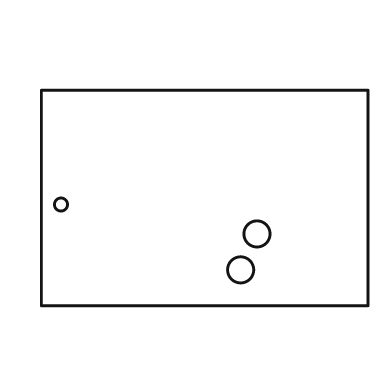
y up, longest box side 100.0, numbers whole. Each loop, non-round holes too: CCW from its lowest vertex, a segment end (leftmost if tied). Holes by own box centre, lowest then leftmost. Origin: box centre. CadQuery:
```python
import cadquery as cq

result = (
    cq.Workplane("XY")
    .moveTo(-50.0, -33.0)
    .lineTo(50.0, -33.0)
    .lineTo(50.0, 33.0)
    .lineTo(-50.0, 33.0)
    .close()
    .moveTo(11.0, -22.0)
    .circle(4.0)
    .moveTo(16.0, -11.0)
    .circle(4.0)
    .moveTo(-44.0, -2.0)
    .circle(2.0)
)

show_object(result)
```